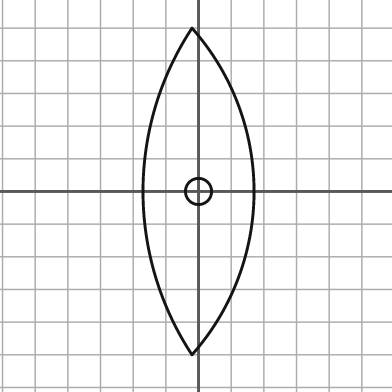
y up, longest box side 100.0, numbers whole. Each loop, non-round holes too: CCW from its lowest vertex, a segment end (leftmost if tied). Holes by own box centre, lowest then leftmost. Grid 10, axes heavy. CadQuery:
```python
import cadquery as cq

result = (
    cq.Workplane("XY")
    .moveTo(-2.0, -50.0)
    .threePointArc((17.0, 0.0), (-2.0, 50.0))
    .threePointArc((-17.0, 0.0), (-2.0, -50.0))
    .close()
    .moveTo(0.0, 0.0)
    .circle(4.0)
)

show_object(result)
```